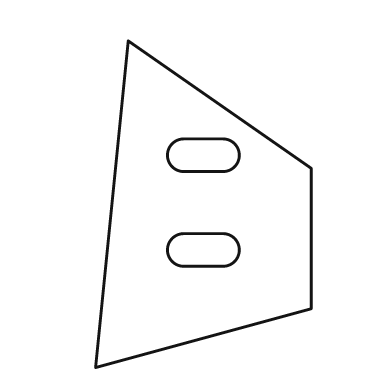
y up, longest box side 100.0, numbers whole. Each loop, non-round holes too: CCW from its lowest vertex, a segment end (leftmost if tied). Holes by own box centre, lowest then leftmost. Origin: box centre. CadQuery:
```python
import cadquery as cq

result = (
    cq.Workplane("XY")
    .moveTo(-33.0, -50.0)
    .lineTo(33.0, -32.0)
    .lineTo(33.0, 11.0)
    .lineTo(-23.0, 50.0)
    .close()
    .moveTo(-6.0, -19.0)
    .lineTo(6.0, -19.0)
    .threePointArc((11.0, -14.0), (6.0, -9.0))
    .lineTo(-6.0, -9.0)
    .threePointArc((-11.0, -14.0), (-6.0, -19.0))
    .close()
    .moveTo(-6.0, 10.0)
    .lineTo(6.0, 10.0)
    .threePointArc((11.0, 15.0), (6.0, 20.0))
    .lineTo(-6.0, 20.0)
    .threePointArc((-11.0, 15.0), (-6.0, 10.0))
    .close()
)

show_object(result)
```